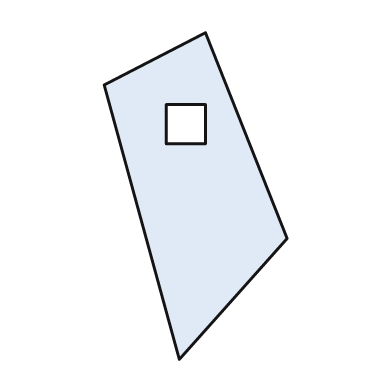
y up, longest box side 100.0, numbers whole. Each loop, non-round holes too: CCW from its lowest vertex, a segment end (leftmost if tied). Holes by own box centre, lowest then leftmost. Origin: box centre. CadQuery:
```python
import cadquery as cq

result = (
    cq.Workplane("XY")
    .moveTo(-5.0, -50.0)
    .lineTo(28.0, -13.0)
    .lineTo(3.0, 50.0)
    .lineTo(-28.0, 34.0)
    .close()
    .moveTo(-9.0, 16.0)
    .lineTo(3.0, 16.0)
    .lineTo(3.0, 28.0)
    .lineTo(-9.0, 28.0)
    .close()
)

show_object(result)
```